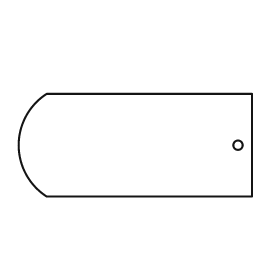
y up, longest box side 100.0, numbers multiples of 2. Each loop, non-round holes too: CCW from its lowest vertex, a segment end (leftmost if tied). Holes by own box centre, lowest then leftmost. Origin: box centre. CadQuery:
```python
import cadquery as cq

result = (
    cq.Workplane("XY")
    .moveTo(-38.0, -22.0)
    .lineTo(50.0, -22.0)
    .lineTo(50.0, 22.0)
    .lineTo(-38.0, 22.0)
    .threePointArc((-50.0, 0.0), (-38.0, -22.0))
    .close()
    .moveTo(44.0, 0.0)
    .circle(2.0)
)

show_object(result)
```